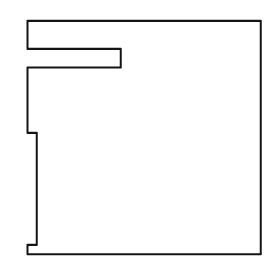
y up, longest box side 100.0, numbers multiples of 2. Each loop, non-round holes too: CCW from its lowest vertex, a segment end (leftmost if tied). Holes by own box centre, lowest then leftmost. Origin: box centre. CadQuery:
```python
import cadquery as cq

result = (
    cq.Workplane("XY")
    .moveTo(-50.0, -50.0)
    .lineTo(50.0, -50.0)
    .lineTo(50.0, 50.0)
    .lineTo(-50.0, 50.0)
    .lineTo(-50.0, 38.0)
    .lineTo(-10.0, 38.0)
    .lineTo(-10.0, 30.0)
    .lineTo(-50.0, 30.0)
    .lineTo(-50.0, 2.0)
    .lineTo(-46.0, 2.0)
    .lineTo(-46.0, -46.0)
    .lineTo(-50.0, -46.0)
    .close()
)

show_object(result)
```